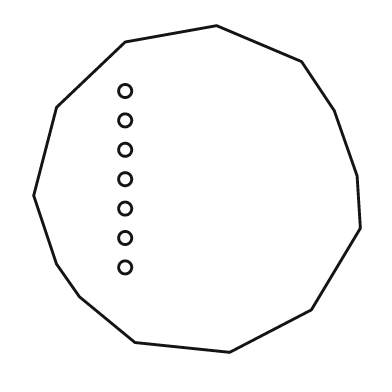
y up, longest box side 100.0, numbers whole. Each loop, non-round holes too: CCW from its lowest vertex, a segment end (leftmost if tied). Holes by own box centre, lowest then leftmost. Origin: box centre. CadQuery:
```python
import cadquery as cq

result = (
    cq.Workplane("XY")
    .moveTo(10.0, -50.0)
    .lineTo(35.0, -37.0)
    .lineTo(50.0, -12.0)
    .lineTo(49.0, 4.0)
    .lineTo(42.0, 24.0)
    .lineTo(32.0, 39.0)
    .lineTo(6.0, 50.0)
    .lineTo(-22.0, 45.0)
    .lineTo(-43.0, 25.0)
    .lineTo(-50.0, -2.0)
    .lineTo(-43.0, -23.0)
    .lineTo(-36.0, -33.0)
    .lineTo(-19.0, -47.0)
    .close()
    .moveTo(-22.0, -24.0)
    .circle(2.0)
    .moveTo(-22.0, -15.0)
    .circle(2.0)
    .moveTo(-22.0, -6.0)
    .circle(2.0)
    .moveTo(-22.0, 3.0)
    .circle(2.0)
    .moveTo(-22.0, 12.0)
    .circle(2.0)
    .moveTo(-22.0, 21.0)
    .circle(2.0)
    .moveTo(-22.0, 30.0)
    .circle(2.0)
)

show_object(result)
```